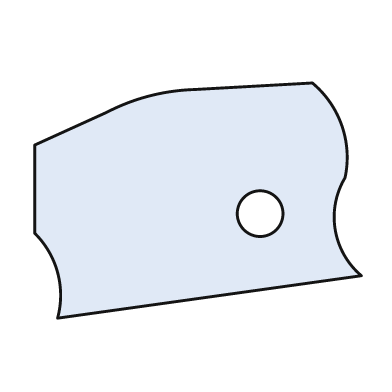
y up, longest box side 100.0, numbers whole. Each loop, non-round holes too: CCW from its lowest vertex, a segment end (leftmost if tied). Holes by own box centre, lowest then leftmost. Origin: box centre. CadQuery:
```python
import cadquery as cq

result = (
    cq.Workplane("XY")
    .moveTo(-43.0, -36.0)
    .lineTo(50.0, -23.0)
    .threePointArc((42.0, -9.0), (45.0, 7.0))
    .threePointArc((44.0, 23.0), (35.0, 36.0))
    .lineTo(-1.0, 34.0)
    .threePointArc((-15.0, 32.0), (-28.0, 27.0))
    .lineTo(-50.0, 17.0)
    .lineTo(-50.0, -10.0)
    .threePointArc((-43.0, -22.0), (-43.0, -36.0))
    .close()
    .moveTo(19.0, -4.0)
    .circle(7.0)
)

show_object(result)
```